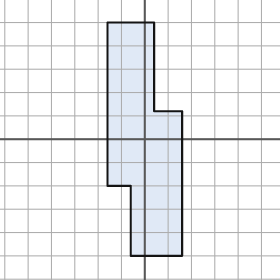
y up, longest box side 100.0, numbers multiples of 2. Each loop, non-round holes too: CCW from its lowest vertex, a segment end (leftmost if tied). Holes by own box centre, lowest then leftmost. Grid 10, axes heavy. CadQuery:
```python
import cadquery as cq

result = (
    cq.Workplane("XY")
    .moveTo(-6.0, -50.0)
    .lineTo(16.0, -50.0)
    .lineTo(16.0, 12.0)
    .lineTo(4.0, 12.0)
    .lineTo(4.0, 50.0)
    .lineTo(-16.0, 50.0)
    .lineTo(-16.0, -20.0)
    .lineTo(-6.0, -20.0)
    .close()
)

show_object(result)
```